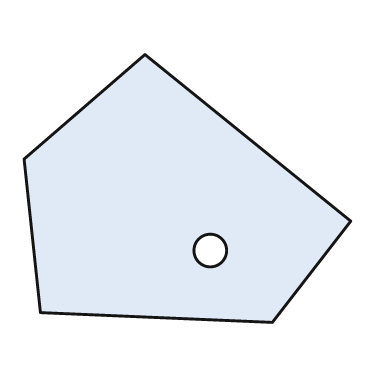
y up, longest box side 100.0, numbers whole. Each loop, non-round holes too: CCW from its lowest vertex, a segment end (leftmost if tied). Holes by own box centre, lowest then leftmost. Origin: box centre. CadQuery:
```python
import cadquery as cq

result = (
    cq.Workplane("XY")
    .moveTo(26.0, -41.0)
    .lineTo(50.0, -10.0)
    .lineTo(-13.0, 41.0)
    .lineTo(-50.0, 9.0)
    .lineTo(-45.0, -38.0)
    .close()
    .moveTo(7.0, -19.0)
    .circle(5.0)
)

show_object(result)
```